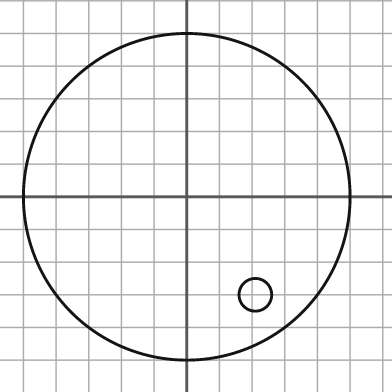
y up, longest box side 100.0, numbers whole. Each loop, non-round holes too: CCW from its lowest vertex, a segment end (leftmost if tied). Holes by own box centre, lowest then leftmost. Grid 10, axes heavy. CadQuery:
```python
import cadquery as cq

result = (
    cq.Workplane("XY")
    .moveTo(0.0, 0.0)
    .circle(50.0)
    .moveTo(21.0, -30.0)
    .circle(5.0)
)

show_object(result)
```